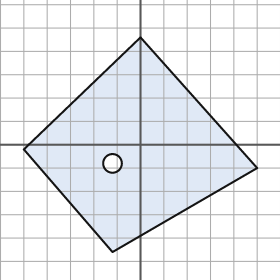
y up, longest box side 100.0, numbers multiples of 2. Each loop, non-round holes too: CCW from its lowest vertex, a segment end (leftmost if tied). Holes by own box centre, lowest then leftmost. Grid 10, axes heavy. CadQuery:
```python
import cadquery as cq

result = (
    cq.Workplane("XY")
    .moveTo(-12.0, -46.0)
    .lineTo(50.0, -10.0)
    .lineTo(0.0, 46.0)
    .lineTo(-50.0, -2.0)
    .close()
    .moveTo(-12.0, -8.0)
    .circle(4.0)
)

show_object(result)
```